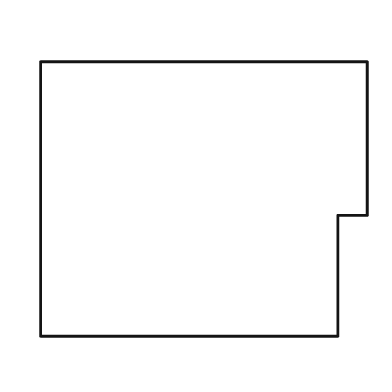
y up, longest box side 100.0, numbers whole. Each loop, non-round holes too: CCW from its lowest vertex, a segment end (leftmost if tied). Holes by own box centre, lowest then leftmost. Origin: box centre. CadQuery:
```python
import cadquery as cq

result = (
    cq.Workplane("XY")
    .moveTo(-50.0, -42.0)
    .lineTo(41.0, -42.0)
    .lineTo(41.0, -5.0)
    .lineTo(50.0, -5.0)
    .lineTo(50.0, 42.0)
    .lineTo(-50.0, 42.0)
    .close()
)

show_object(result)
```